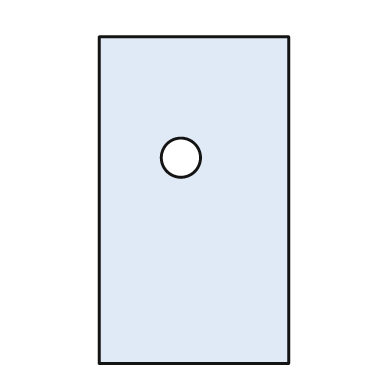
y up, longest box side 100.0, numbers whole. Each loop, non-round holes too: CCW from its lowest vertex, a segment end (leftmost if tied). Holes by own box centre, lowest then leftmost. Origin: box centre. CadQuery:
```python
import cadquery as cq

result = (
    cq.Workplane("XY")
    .moveTo(-29.0, -50.0)
    .lineTo(29.0, -50.0)
    .lineTo(29.0, 50.0)
    .lineTo(-29.0, 50.0)
    .close()
    .moveTo(-4.0, 13.0)
    .circle(6.0)
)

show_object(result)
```